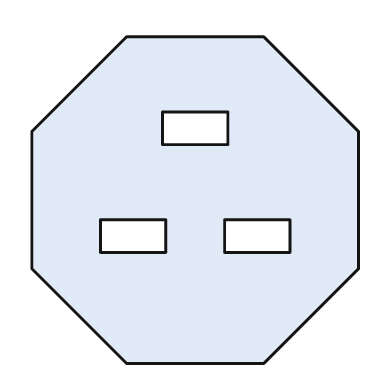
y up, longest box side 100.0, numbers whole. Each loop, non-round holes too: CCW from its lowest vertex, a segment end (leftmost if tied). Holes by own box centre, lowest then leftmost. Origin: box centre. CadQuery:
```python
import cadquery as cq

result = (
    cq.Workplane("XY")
    .moveTo(-21.0, -50.0)
    .lineTo(21.0, -50.0)
    .lineTo(50.0, -21.0)
    .lineTo(50.0, 21.0)
    .lineTo(21.0, 50.0)
    .lineTo(-21.0, 50.0)
    .lineTo(-50.0, 21.0)
    .lineTo(-50.0, -21.0)
    .close()
    .moveTo(-29.0, -16.0)
    .lineTo(-9.0, -16.0)
    .lineTo(-9.0, -6.0)
    .lineTo(-29.0, -6.0)
    .close()
    .moveTo(9.0, -16.0)
    .lineTo(29.0, -16.0)
    .lineTo(29.0, -6.0)
    .lineTo(9.0, -6.0)
    .close()
    .moveTo(-10.0, 17.0)
    .lineTo(10.0, 17.0)
    .lineTo(10.0, 27.0)
    .lineTo(-10.0, 27.0)
    .close()
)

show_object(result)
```